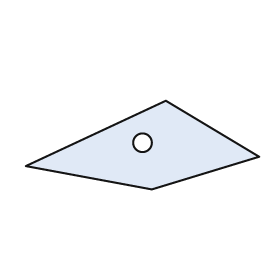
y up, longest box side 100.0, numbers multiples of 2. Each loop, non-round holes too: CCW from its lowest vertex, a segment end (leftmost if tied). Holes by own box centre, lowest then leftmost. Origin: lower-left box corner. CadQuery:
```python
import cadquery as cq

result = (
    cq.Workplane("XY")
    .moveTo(54.0, 0.0)
    .lineTo(100.0, 14.0)
    .lineTo(60.0, 38.0)
    .lineTo(0.0, 10.0)
    .close()
    .moveTo(50.0, 20.0)
    .circle(4.0)
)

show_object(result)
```